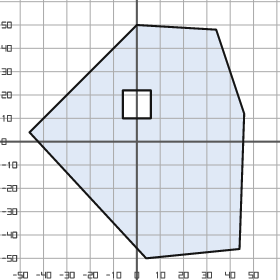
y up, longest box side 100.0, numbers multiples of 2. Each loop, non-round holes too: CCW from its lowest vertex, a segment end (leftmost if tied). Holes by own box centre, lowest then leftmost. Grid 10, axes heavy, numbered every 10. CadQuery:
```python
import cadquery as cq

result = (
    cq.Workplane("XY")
    .moveTo(4.0, -50.0)
    .lineTo(44.0, -46.0)
    .lineTo(46.0, 12.0)
    .lineTo(34.0, 48.0)
    .lineTo(0.0, 50.0)
    .lineTo(-46.0, 4.0)
    .close()
    .moveTo(-6.0, 10.0)
    .lineTo(6.0, 10.0)
    .lineTo(6.0, 22.0)
    .lineTo(-6.0, 22.0)
    .close()
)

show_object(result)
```